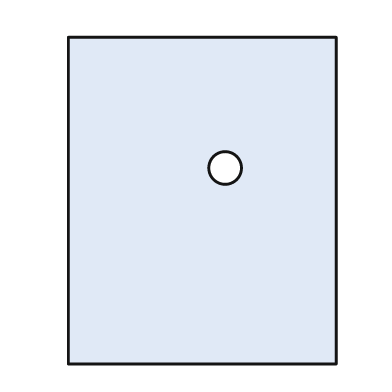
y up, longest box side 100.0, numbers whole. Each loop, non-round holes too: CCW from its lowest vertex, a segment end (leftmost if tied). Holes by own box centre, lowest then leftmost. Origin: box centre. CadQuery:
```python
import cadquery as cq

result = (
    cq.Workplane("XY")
    .moveTo(-41.0, -50.0)
    .lineTo(41.0, -50.0)
    .lineTo(41.0, 50.0)
    .lineTo(-41.0, 50.0)
    .close()
    .moveTo(7.0, 10.0)
    .circle(5.0)
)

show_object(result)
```